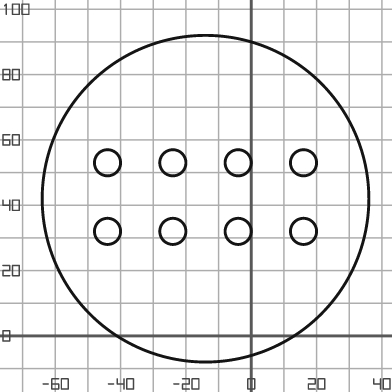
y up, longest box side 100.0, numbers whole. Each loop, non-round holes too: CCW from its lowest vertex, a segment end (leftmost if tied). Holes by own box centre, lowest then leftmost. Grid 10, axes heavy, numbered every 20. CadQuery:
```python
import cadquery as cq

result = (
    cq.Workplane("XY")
    .moveTo(-14.0, 42.0)
    .circle(50.0)
    .moveTo(-44.0, 32.0)
    .circle(4.0)
    .moveTo(-24.0, 32.0)
    .circle(4.0)
    .moveTo(-4.0, 32.0)
    .circle(4.0)
    .moveTo(16.0, 32.0)
    .circle(4.0)
    .moveTo(-44.0, 53.0)
    .circle(4.0)
    .moveTo(-24.0, 53.0)
    .circle(4.0)
    .moveTo(-4.0, 53.0)
    .circle(4.0)
    .moveTo(16.0, 53.0)
    .circle(4.0)
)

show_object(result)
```